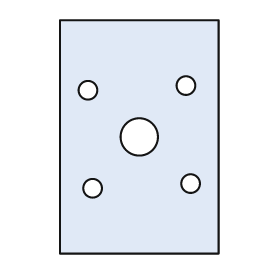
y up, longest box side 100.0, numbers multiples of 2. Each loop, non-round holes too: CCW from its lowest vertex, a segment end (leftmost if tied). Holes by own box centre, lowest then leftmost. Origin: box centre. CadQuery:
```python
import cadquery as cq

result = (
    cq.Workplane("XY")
    .moveTo(-34.0, -50.0)
    .lineTo(34.0, -50.0)
    .lineTo(34.0, 50.0)
    .lineTo(-34.0, 50.0)
    .close()
    .moveTo(-20.0, -22.0)
    .circle(4.0)
    .moveTo(22.0, -20.0)
    .circle(4.0)
    .moveTo(0.0, 0.0)
    .circle(8.0)
    .moveTo(-22.0, 20.0)
    .circle(4.0)
    .moveTo(20.0, 22.0)
    .circle(4.0)
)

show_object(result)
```